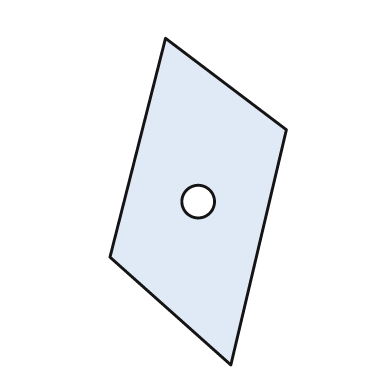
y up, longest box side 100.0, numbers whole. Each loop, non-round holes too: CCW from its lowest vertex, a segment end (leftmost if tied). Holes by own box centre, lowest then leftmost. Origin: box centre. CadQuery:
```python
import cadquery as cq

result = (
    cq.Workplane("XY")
    .moveTo(10.0, -50.0)
    .lineTo(27.0, 22.0)
    .lineTo(-10.0, 50.0)
    .lineTo(-27.0, -17.0)
    .close()
    .moveTo(0.0, 0.0)
    .circle(5.0)
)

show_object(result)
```